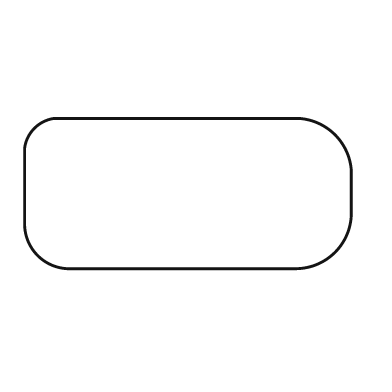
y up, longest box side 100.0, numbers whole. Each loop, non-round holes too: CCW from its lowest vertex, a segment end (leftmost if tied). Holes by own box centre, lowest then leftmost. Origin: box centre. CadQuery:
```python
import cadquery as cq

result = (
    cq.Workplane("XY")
    .moveTo(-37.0, -23.0)
    .lineTo(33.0, -23.0)
    .threePointArc((45.0, -18.0), (50.0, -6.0))
    .lineTo(50.0, 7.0)
    .threePointArc((45.0, 18.0), (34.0, 23.0))
    .lineTo(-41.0, 23.0)
    .threePointArc((-47.0, 20.0), (-50.0, 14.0))
    .lineTo(-50.0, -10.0)
    .threePointArc((-46.0, -19.0), (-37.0, -23.0))
    .close()
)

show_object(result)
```